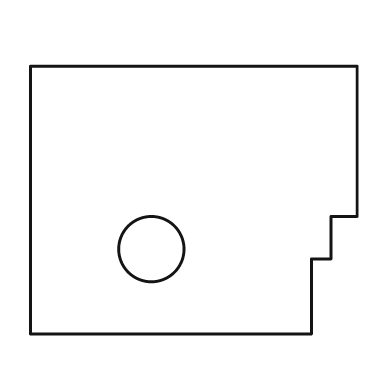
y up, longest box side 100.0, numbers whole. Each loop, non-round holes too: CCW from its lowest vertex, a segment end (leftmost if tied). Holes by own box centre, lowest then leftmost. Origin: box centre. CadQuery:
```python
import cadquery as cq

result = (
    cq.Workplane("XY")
    .moveTo(-50.0, -41.0)
    .lineTo(36.0, -41.0)
    .lineTo(36.0, -18.0)
    .lineTo(42.0, -18.0)
    .lineTo(42.0, -5.0)
    .lineTo(50.0, -5.0)
    .lineTo(50.0, 41.0)
    .lineTo(-50.0, 41.0)
    .close()
    .moveTo(-13.0, -15.0)
    .circle(10.0)
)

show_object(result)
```